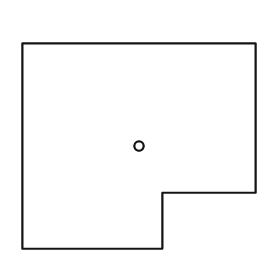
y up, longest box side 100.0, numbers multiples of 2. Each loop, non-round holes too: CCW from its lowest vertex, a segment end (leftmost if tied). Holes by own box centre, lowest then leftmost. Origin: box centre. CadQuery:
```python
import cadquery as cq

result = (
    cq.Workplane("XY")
    .moveTo(-50.0, -44.0)
    .lineTo(10.0, -44.0)
    .lineTo(10.0, -20.0)
    .lineTo(50.0, -20.0)
    .lineTo(50.0, 44.0)
    .lineTo(-50.0, 44.0)
    .close()
    .moveTo(0.0, 0.0)
    .circle(2.0)
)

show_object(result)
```